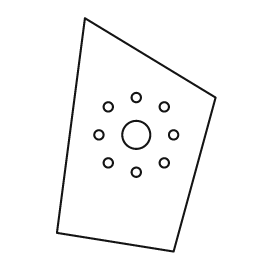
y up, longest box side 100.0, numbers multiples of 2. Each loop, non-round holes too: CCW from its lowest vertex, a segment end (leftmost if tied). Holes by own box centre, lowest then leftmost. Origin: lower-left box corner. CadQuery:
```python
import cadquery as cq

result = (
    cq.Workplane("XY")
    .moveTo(50.0, 0.0)
    .lineTo(68.0, 66.0)
    .lineTo(12.0, 100.0)
    .lineTo(0.0, 8.0)
    .close()
    .moveTo(34.0, 34.0)
    .circle(2.0)
    .moveTo(22.0, 38.0)
    .circle(2.0)
    .moveTo(46.0, 38.0)
    .circle(2.0)
    .moveTo(18.0, 50.0)
    .circle(2.0)
    .moveTo(34.0, 50.0)
    .circle(6.0)
    .moveTo(50.0, 50.0)
    .circle(2.0)
    .moveTo(22.0, 62.0)
    .circle(2.0)
    .moveTo(46.0, 62.0)
    .circle(2.0)
    .moveTo(34.0, 66.0)
    .circle(2.0)
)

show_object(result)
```